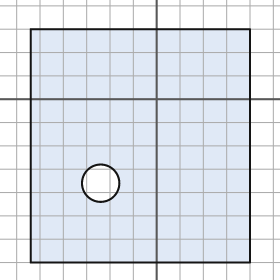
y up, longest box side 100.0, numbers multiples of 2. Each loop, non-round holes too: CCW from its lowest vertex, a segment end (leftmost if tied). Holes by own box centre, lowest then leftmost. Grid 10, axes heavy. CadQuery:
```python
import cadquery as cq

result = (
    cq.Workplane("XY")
    .moveTo(-54.0, -70.0)
    .lineTo(40.0, -70.0)
    .lineTo(40.0, 30.0)
    .lineTo(-54.0, 30.0)
    .close()
    .moveTo(-24.0, -36.0)
    .circle(8.0)
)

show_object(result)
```